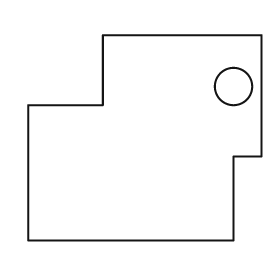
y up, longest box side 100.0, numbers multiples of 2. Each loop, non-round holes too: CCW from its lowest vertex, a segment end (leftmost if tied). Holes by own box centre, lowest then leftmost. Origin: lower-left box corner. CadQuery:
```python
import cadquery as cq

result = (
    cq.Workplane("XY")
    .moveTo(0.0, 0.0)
    .lineTo(88.0, 0.0)
    .lineTo(88.0, 36.0)
    .lineTo(100.0, 36.0)
    .lineTo(100.0, 88.0)
    .lineTo(32.0, 88.0)
    .lineTo(32.0, 58.0)
    .lineTo(0.0, 58.0)
    .close()
    .moveTo(88.0, 66.0)
    .circle(8.0)
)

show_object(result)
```